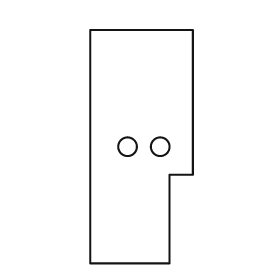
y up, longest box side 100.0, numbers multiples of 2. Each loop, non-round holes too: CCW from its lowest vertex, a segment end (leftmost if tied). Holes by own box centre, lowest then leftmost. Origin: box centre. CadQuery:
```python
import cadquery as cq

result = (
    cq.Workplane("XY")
    .moveTo(-22.0, -50.0)
    .lineTo(12.0, -50.0)
    .lineTo(12.0, -12.0)
    .lineTo(22.0, -12.0)
    .lineTo(22.0, 50.0)
    .lineTo(-22.0, 50.0)
    .close()
    .moveTo(-6.0, 0.0)
    .circle(4.0)
    .moveTo(8.0, 0.0)
    .circle(4.0)
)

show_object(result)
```